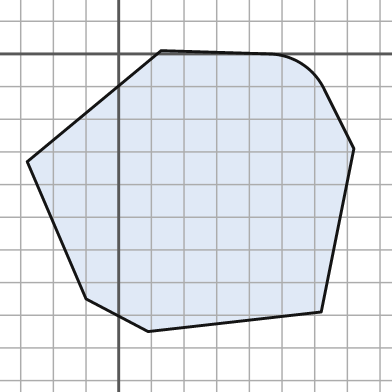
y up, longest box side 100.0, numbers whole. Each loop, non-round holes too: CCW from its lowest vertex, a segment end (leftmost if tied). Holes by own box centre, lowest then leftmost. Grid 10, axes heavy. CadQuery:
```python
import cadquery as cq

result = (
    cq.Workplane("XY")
    .moveTo(9.0, -85.0)
    .lineTo(62.0, -79.0)
    .lineTo(72.0, -29.0)
    .lineTo(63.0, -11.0)
    .threePointArc((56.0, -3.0), (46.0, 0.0))
    .lineTo(13.0, 1.0)
    .lineTo(-28.0, -33.0)
    .lineTo(-10.0, -75.0)
    .close()
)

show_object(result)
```